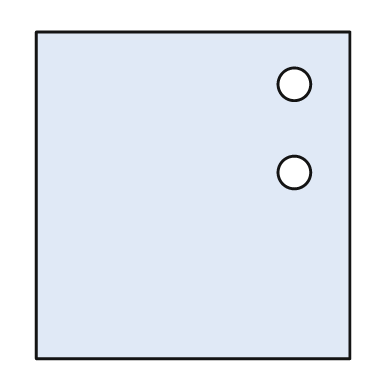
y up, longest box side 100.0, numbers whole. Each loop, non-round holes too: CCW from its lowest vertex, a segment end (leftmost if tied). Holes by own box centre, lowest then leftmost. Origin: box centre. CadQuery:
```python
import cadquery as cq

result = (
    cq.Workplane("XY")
    .moveTo(-48.0, -50.0)
    .lineTo(48.0, -50.0)
    .lineTo(48.0, 50.0)
    .lineTo(-48.0, 50.0)
    .close()
    .moveTo(31.0, 7.0)
    .circle(5.0)
    .moveTo(31.0, 34.0)
    .circle(5.0)
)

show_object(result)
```